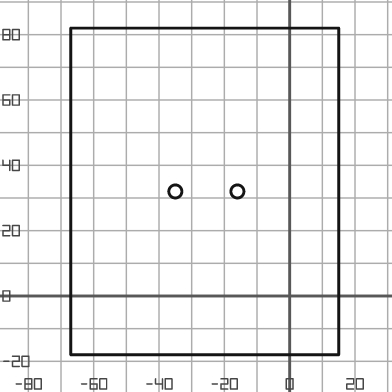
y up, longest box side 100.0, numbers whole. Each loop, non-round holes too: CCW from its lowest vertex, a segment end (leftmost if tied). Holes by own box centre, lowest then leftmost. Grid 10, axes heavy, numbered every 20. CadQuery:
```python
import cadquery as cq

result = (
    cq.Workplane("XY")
    .moveTo(-67.0, -18.0)
    .lineTo(15.0, -18.0)
    .lineTo(15.0, 82.0)
    .lineTo(-67.0, 82.0)
    .close()
    .moveTo(-35.0, 32.0)
    .circle(2.0)
    .moveTo(-16.0, 32.0)
    .circle(2.0)
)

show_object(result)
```